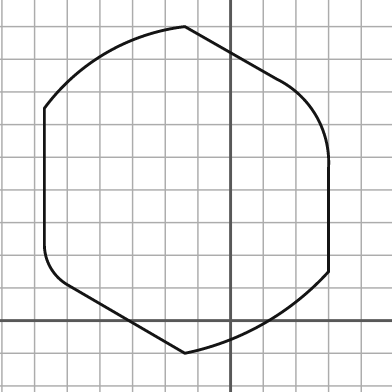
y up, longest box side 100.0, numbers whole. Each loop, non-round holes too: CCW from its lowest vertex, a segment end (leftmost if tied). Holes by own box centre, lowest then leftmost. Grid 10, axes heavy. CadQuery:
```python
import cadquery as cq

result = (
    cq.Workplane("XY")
    .moveTo(-14.0, -10.0)
    .threePointArc((10.0, -1.0), (30.0, 15.0))
    .lineTo(30.0, 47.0)
    .threePointArc((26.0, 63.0), (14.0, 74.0))
    .lineTo(-14.0, 90.0)
    .threePointArc((-38.0, 82.0), (-57.0, 65.0))
    .lineTo(-57.0, 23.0)
    .threePointArc((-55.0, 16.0), (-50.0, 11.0))
    .close()
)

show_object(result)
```